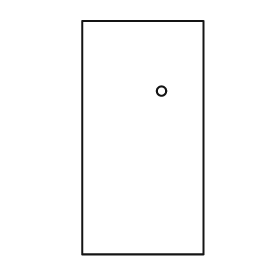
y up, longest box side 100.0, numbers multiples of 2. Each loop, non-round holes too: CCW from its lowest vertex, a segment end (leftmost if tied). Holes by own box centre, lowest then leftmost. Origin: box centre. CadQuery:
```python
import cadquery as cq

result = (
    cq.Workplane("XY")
    .moveTo(-26.0, -50.0)
    .lineTo(26.0, -50.0)
    .lineTo(26.0, 50.0)
    .lineTo(-26.0, 50.0)
    .close()
    .moveTo(8.0, 20.0)
    .circle(2.0)
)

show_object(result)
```